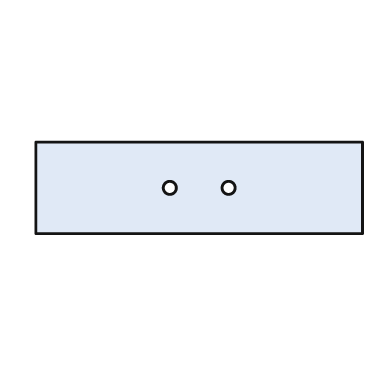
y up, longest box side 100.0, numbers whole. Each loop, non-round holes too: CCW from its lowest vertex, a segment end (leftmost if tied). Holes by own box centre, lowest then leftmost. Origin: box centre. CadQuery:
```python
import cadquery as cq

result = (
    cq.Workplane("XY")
    .moveTo(-50.0, -14.0)
    .lineTo(50.0, -14.0)
    .lineTo(50.0, 14.0)
    .lineTo(-50.0, 14.0)
    .close()
    .moveTo(-9.0, 0.0)
    .circle(2.0)
    .moveTo(9.0, 0.0)
    .circle(2.0)
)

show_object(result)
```